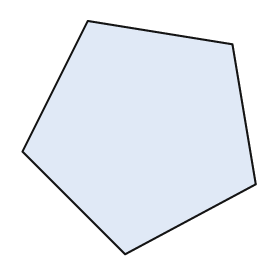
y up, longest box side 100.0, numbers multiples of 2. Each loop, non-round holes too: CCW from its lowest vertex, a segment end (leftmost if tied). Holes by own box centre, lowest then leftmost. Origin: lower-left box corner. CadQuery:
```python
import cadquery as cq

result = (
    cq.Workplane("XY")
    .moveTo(44.0, 0.0)
    .lineTo(100.0, 30.0)
    .lineTo(90.0, 90.0)
    .lineTo(28.0, 100.0)
    .lineTo(0.0, 44.0)
    .close()
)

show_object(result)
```